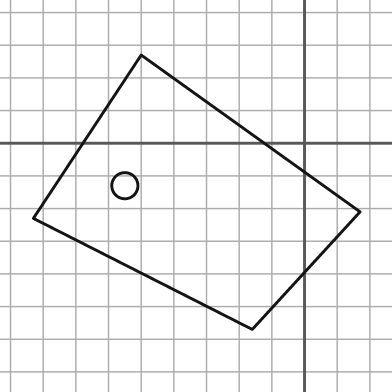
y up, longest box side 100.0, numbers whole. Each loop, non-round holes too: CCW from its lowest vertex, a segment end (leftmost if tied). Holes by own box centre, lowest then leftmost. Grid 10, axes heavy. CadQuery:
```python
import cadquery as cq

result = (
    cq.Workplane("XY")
    .moveTo(-16.0, -57.0)
    .lineTo(17.0, -21.0)
    .lineTo(-50.0, 27.0)
    .lineTo(-83.0, -23.0)
    .close()
    .moveTo(-55.0, -13.0)
    .circle(4.0)
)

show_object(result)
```